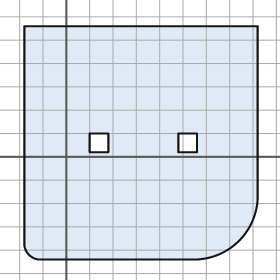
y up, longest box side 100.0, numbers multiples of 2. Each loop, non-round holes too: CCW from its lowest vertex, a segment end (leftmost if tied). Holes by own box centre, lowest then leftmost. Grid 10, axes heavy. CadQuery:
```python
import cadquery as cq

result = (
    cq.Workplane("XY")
    .moveTo(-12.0, -44.0)
    .lineTo(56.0, -44.0)
    .threePointArc((74.0, -36.0), (82.0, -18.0))
    .lineTo(82.0, 56.0)
    .lineTo(-18.0, 56.0)
    .lineTo(-18.0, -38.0)
    .threePointArc((-16.0, -42.0), (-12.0, -44.0))
    .close()
    .moveTo(10.0, 2.0)
    .lineTo(18.0, 2.0)
    .lineTo(18.0, 10.0)
    .lineTo(10.0, 10.0)
    .close()
    .moveTo(48.0, 2.0)
    .lineTo(56.0, 2.0)
    .lineTo(56.0, 10.0)
    .lineTo(48.0, 10.0)
    .close()
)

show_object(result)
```